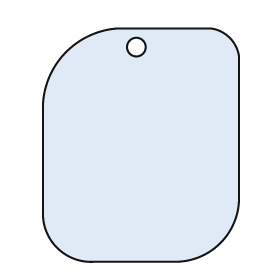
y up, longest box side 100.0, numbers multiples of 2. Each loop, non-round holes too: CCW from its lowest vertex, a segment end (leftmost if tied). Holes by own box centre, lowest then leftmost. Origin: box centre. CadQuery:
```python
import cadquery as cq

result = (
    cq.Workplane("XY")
    .moveTo(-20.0, -50.0)
    .lineTo(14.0, -50.0)
    .threePointArc((34.0, -42.0), (42.0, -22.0))
    .lineTo(42.0, 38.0)
    .threePointArc((38.0, 46.0), (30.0, 50.0))
    .lineTo(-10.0, 50.0)
    .threePointArc((-32.0, 40.0), (-42.0, 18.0))
    .lineTo(-42.0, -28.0)
    .threePointArc((-36.0, -44.0), (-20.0, -50.0))
    .close()
    .moveTo(-2.0, 42.0)
    .circle(4.0)
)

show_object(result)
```